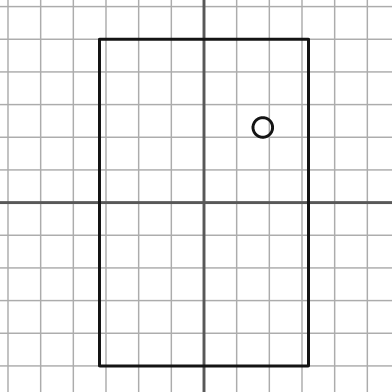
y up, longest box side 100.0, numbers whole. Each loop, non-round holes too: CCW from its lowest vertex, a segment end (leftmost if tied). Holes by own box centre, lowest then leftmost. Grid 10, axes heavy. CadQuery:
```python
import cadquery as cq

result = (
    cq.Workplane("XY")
    .moveTo(-32.0, -50.0)
    .lineTo(32.0, -50.0)
    .lineTo(32.0, 50.0)
    .lineTo(-32.0, 50.0)
    .close()
    .moveTo(18.0, 23.0)
    .circle(3.0)
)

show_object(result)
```